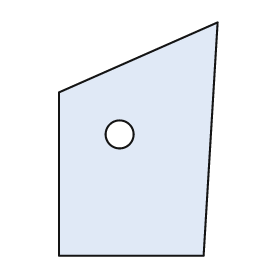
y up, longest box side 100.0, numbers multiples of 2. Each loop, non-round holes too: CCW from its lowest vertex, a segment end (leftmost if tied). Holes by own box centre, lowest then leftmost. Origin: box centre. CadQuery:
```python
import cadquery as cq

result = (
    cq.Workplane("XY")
    .moveTo(-34.0, -50.0)
    .lineTo(28.0, -50.0)
    .lineTo(34.0, 50.0)
    .lineTo(-34.0, 20.0)
    .close()
    .moveTo(-8.0, 2.0)
    .circle(6.0)
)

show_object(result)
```